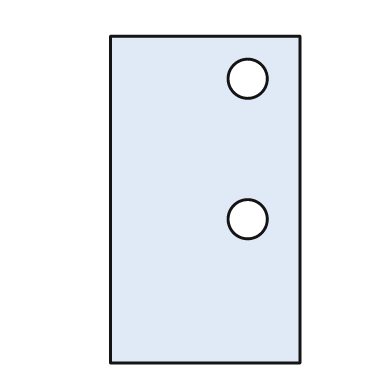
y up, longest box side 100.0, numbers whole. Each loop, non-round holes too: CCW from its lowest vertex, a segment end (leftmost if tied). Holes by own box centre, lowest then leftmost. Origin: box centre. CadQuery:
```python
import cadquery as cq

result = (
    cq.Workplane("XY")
    .moveTo(-29.0, -50.0)
    .lineTo(29.0, -50.0)
    .lineTo(29.0, 50.0)
    .lineTo(-29.0, 50.0)
    .close()
    .moveTo(13.0, -6.0)
    .circle(6.0)
    .moveTo(13.0, 37.0)
    .circle(6.0)
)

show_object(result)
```